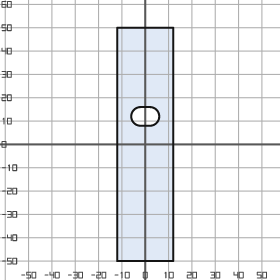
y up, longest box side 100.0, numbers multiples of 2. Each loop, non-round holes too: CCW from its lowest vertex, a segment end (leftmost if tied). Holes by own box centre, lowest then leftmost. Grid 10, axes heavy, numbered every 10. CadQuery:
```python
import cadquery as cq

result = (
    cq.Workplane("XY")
    .moveTo(-12.0, -50.0)
    .lineTo(12.0, -50.0)
    .lineTo(12.0, 50.0)
    .lineTo(-12.0, 50.0)
    .close()
    .moveTo(-2.0, 8.0)
    .lineTo(2.0, 8.0)
    .threePointArc((6.0, 12.0), (2.0, 16.0))
    .lineTo(-2.0, 16.0)
    .threePointArc((-6.0, 12.0), (-2.0, 8.0))
    .close()
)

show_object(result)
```